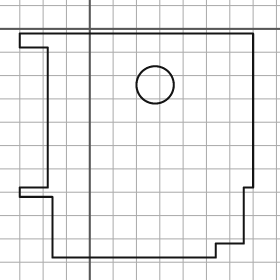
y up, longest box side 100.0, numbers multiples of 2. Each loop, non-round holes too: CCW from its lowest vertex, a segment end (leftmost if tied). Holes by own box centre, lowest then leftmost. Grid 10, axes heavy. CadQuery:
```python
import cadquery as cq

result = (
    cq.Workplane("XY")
    .moveTo(-16.0, -98.0)
    .lineTo(54.0, -98.0)
    .lineTo(54.0, -92.0)
    .lineTo(66.0, -92.0)
    .lineTo(66.0, -68.0)
    .lineTo(70.0, -68.0)
    .lineTo(70.0, -2.0)
    .lineTo(-30.0, -2.0)
    .lineTo(-30.0, -8.0)
    .lineTo(-18.0, -8.0)
    .lineTo(-18.0, -68.0)
    .lineTo(-30.0, -68.0)
    .lineTo(-30.0, -72.0)
    .lineTo(-16.0, -72.0)
    .close()
    .moveTo(28.0, -24.0)
    .circle(8.0)
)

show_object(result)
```